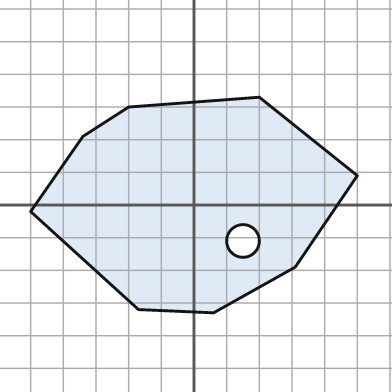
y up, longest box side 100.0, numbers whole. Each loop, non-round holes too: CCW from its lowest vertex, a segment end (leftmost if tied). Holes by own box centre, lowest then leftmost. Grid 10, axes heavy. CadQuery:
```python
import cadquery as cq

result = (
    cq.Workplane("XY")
    .moveTo(6.0, -33.0)
    .lineTo(31.0, -19.0)
    .lineTo(50.0, 9.0)
    .lineTo(20.0, 33.0)
    .lineTo(-20.0, 30.0)
    .lineTo(-34.0, 21.0)
    .lineTo(-50.0, -2.0)
    .lineTo(-17.0, -32.0)
    .close()
    .moveTo(15.0, -11.0)
    .circle(5.0)
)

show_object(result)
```